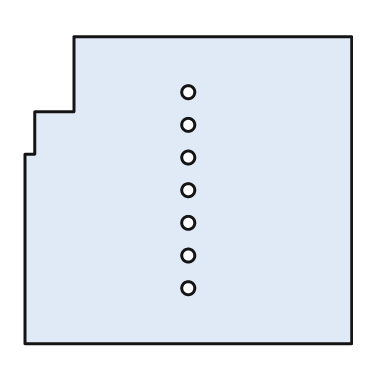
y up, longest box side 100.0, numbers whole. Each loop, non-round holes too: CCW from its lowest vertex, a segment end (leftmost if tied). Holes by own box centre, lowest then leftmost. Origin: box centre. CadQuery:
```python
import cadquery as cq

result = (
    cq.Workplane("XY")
    .moveTo(-50.0, -47.0)
    .lineTo(50.0, -47.0)
    .lineTo(50.0, 47.0)
    .lineTo(-35.0, 47.0)
    .lineTo(-35.0, 24.0)
    .lineTo(-47.0, 24.0)
    .lineTo(-47.0, 11.0)
    .lineTo(-50.0, 11.0)
    .close()
    .moveTo(0.0, -30.0)
    .circle(2.0)
    .moveTo(0.0, -20.0)
    .circle(2.0)
    .moveTo(0.0, -10.0)
    .circle(2.0)
    .moveTo(0.0, 0.0)
    .circle(2.0)
    .moveTo(0.0, 10.0)
    .circle(2.0)
    .moveTo(0.0, 20.0)
    .circle(2.0)
    .moveTo(0.0, 30.0)
    .circle(2.0)
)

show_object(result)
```